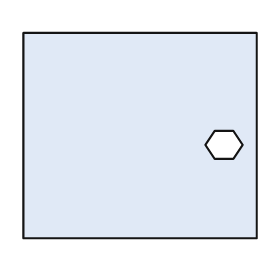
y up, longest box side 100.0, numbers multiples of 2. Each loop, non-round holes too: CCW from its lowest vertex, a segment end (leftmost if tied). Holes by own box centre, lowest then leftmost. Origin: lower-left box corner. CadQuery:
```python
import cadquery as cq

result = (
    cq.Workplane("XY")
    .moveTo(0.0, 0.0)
    .lineTo(100.0, 0.0)
    .lineTo(100.0, 88.0)
    .lineTo(0.0, 88.0)
    .close()
    .moveTo(82.0, 34.0)
    .lineTo(90.0, 34.0)
    .lineTo(94.0, 40.0)
    .lineTo(90.0, 46.0)
    .lineTo(82.0, 46.0)
    .lineTo(78.0, 40.0)
    .close()
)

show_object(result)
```